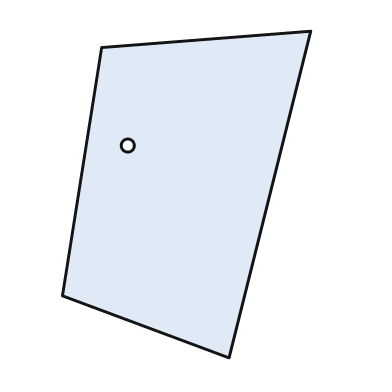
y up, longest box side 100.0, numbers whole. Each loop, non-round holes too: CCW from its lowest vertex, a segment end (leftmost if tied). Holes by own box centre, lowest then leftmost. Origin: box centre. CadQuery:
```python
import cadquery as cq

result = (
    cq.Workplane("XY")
    .moveTo(13.0, -50.0)
    .lineTo(38.0, 50.0)
    .lineTo(-26.0, 45.0)
    .lineTo(-38.0, -31.0)
    .close()
    .moveTo(-18.0, 15.0)
    .circle(2.0)
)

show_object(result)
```